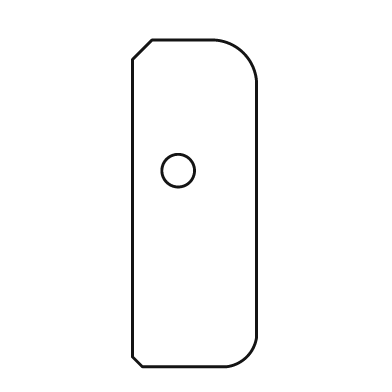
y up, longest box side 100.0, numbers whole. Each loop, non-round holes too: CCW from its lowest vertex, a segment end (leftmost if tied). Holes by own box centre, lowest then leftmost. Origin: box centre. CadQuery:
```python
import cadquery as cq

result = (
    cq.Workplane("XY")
    .moveTo(-16.0, -50.0)
    .lineTo(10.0, -50.0)
    .threePointArc((16.0, -47.0), (19.0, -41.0))
    .lineTo(19.0, 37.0)
    .threePointArc((15.0, 46.0), (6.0, 50.0))
    .lineTo(-13.0, 50.0)
    .lineTo(-19.0, 44.0)
    .lineTo(-19.0, -47.0)
    .close()
    .moveTo(-5.0, 10.0)
    .circle(5.0)
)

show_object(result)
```